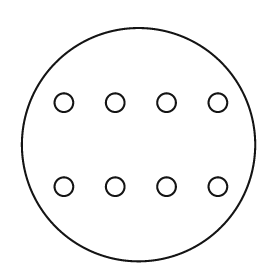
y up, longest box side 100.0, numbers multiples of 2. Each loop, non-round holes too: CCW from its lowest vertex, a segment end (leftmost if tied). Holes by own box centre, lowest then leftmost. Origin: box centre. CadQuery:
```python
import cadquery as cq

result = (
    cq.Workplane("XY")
    .moveTo(0.0, 0.0)
    .circle(50.0)
    .moveTo(-32.0, -18.0)
    .circle(4.0)
    .moveTo(-10.0, -18.0)
    .circle(4.0)
    .moveTo(12.0, -18.0)
    .circle(4.0)
    .moveTo(34.0, -18.0)
    .circle(4.0)
    .moveTo(-32.0, 18.0)
    .circle(4.0)
    .moveTo(-10.0, 18.0)
    .circle(4.0)
    .moveTo(12.0, 18.0)
    .circle(4.0)
    .moveTo(34.0, 18.0)
    .circle(4.0)
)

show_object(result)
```